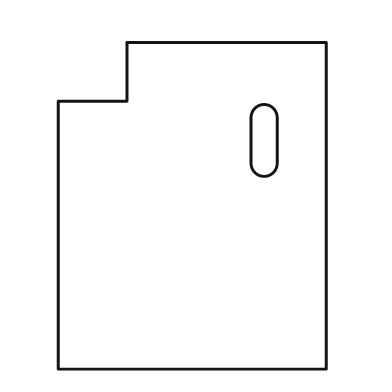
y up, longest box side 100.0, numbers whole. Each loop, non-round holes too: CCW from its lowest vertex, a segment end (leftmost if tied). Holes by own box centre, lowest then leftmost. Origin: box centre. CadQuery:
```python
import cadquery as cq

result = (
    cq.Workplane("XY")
    .moveTo(-41.0, -50.0)
    .lineTo(41.0, -50.0)
    .lineTo(41.0, 50.0)
    .lineTo(-20.0, 50.0)
    .lineTo(-20.0, 32.0)
    .lineTo(-41.0, 32.0)
    .close()
    .moveTo(18.0, 13.0)
    .threePointArc((22.0, 9.0), (26.0, 13.0))
    .lineTo(26.0, 27.0)
    .threePointArc((22.0, 31.0), (18.0, 27.0))
    .close()
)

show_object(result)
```